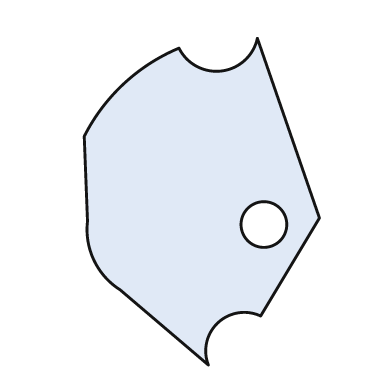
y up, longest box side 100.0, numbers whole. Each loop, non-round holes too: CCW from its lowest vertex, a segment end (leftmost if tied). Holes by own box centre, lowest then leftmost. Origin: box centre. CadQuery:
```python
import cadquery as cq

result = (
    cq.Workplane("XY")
    .moveTo(2.0, -50.0)
    .threePointArc((5.0, -37.0), (18.0, -35.0))
    .lineTo(36.0, -5.0)
    .lineTo(17.0, 50.0)
    .threePointArc((6.0, 40.0), (-7.0, 47.0))
    .threePointArc((-24.0, 36.0), (-36.0, 20.0))
    .lineTo(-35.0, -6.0)
    .threePointArc((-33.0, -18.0), (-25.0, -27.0))
    .close()
    .moveTo(19.0, -7.0)
    .circle(7.0)
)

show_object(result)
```